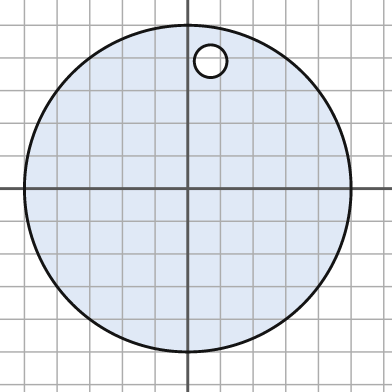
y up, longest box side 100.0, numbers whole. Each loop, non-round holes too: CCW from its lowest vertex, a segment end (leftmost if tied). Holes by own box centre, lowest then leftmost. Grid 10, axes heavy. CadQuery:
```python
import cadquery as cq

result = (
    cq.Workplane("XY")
    .moveTo(0.0, 0.0)
    .circle(50.0)
    .moveTo(7.0, 39.0)
    .circle(5.0)
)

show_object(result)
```